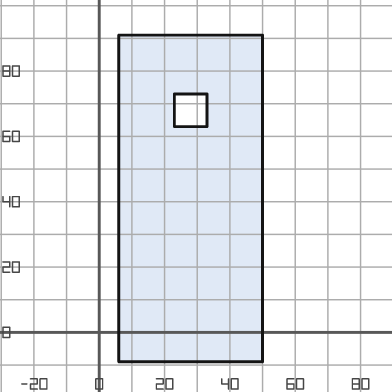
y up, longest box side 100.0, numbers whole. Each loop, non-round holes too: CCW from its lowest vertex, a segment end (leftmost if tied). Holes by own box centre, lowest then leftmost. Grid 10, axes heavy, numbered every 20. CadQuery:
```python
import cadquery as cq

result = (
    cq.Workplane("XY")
    .moveTo(6.0, -9.0)
    .lineTo(50.0, -9.0)
    .lineTo(50.0, 91.0)
    .lineTo(6.0, 91.0)
    .close()
    .moveTo(23.0, 63.0)
    .lineTo(33.0, 63.0)
    .lineTo(33.0, 73.0)
    .lineTo(23.0, 73.0)
    .close()
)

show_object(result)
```